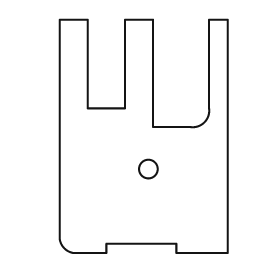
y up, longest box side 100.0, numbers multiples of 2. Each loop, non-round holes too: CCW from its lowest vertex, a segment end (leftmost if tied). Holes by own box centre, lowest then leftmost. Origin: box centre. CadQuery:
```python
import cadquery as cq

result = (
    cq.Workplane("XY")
    .moveTo(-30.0, -50.0)
    .lineTo(-16.0, -50.0)
    .lineTo(-16.0, -46.0)
    .lineTo(14.0, -46.0)
    .lineTo(14.0, -50.0)
    .lineTo(36.0, -50.0)
    .lineTo(36.0, 50.0)
    .lineTo(28.0, 50.0)
    .lineTo(28.0, 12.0)
    .threePointArc((26.0, 6.0), (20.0, 4.0))
    .lineTo(4.0, 4.0)
    .lineTo(4.0, 50.0)
    .lineTo(-8.0, 50.0)
    .lineTo(-8.0, 12.0)
    .lineTo(-24.0, 12.0)
    .lineTo(-24.0, 50.0)
    .lineTo(-36.0, 50.0)
    .lineTo(-36.0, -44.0)
    .threePointArc((-34.0, -48.0), (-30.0, -50.0))
    .close()
    .moveTo(2.0, -14.0)
    .circle(4.0)
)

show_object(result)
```